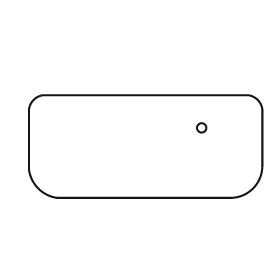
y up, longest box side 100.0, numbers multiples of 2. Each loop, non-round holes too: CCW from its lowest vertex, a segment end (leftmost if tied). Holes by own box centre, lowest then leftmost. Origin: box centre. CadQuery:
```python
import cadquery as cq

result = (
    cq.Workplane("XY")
    .moveTo(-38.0, -22.0)
    .lineTo(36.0, -22.0)
    .threePointArc((46.0, -18.0), (50.0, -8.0))
    .lineTo(50.0, 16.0)
    .threePointArc((48.0, 20.0), (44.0, 22.0))
    .lineTo(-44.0, 22.0)
    .threePointArc((-48.0, 20.0), (-50.0, 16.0))
    .lineTo(-50.0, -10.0)
    .threePointArc((-46.0, -18.0), (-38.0, -22.0))
    .close()
    .moveTo(24.0, 8.0)
    .circle(2.0)
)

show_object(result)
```